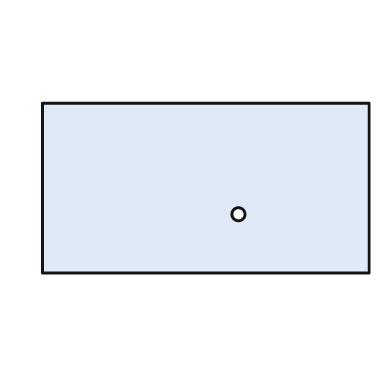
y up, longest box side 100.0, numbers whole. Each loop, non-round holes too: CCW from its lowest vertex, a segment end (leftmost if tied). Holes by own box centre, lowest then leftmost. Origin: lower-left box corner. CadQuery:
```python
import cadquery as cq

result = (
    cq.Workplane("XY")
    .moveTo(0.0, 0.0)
    .lineTo(100.0, 0.0)
    .lineTo(100.0, 52.0)
    .lineTo(0.0, 52.0)
    .close()
    .moveTo(60.0, 18.0)
    .circle(2.0)
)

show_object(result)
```